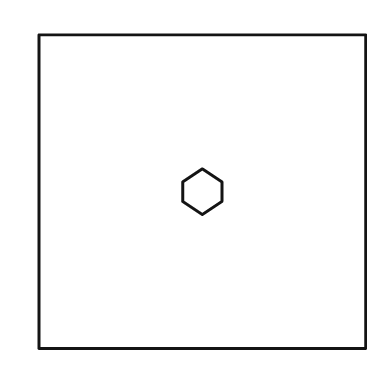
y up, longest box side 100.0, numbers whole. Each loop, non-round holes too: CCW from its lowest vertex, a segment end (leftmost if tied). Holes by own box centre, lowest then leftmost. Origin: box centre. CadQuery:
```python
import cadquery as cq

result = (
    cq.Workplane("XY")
    .moveTo(-50.0, -48.0)
    .lineTo(50.0, -48.0)
    .lineTo(50.0, 48.0)
    .lineTo(-50.0, 48.0)
    .close()
    .moveTo(0.0, -7.0)
    .lineTo(6.0, -3.0)
    .lineTo(6.0, 3.0)
    .lineTo(0.0, 7.0)
    .lineTo(-6.0, 3.0)
    .lineTo(-6.0, -3.0)
    .close()
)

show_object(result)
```